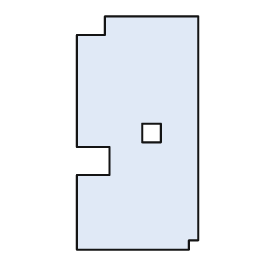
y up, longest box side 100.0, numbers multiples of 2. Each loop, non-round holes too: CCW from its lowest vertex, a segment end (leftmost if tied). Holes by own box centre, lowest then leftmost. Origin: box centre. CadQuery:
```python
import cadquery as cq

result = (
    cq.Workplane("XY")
    .moveTo(-26.0, -50.0)
    .lineTo(22.0, -50.0)
    .lineTo(22.0, -46.0)
    .lineTo(26.0, -46.0)
    .lineTo(26.0, 50.0)
    .lineTo(-14.0, 50.0)
    .lineTo(-14.0, 42.0)
    .lineTo(-26.0, 42.0)
    .lineTo(-26.0, -6.0)
    .lineTo(-12.0, -6.0)
    .lineTo(-12.0, -18.0)
    .lineTo(-26.0, -18.0)
    .close()
    .moveTo(2.0, -4.0)
    .lineTo(10.0, -4.0)
    .lineTo(10.0, 4.0)
    .lineTo(2.0, 4.0)
    .close()
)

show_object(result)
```